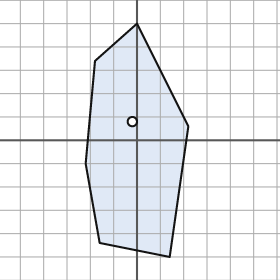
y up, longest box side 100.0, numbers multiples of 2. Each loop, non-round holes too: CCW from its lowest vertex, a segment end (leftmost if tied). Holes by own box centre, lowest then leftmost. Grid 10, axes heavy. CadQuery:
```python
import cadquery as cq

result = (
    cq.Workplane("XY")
    .moveTo(14.0, -50.0)
    .lineTo(22.0, 6.0)
    .lineTo(0.0, 50.0)
    .lineTo(-18.0, 34.0)
    .lineTo(-22.0, -10.0)
    .lineTo(-16.0, -44.0)
    .close()
    .moveTo(-2.0, 8.0)
    .circle(2.0)
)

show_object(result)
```